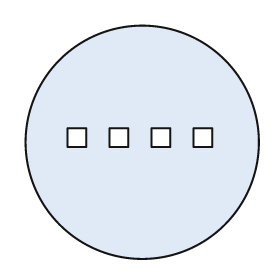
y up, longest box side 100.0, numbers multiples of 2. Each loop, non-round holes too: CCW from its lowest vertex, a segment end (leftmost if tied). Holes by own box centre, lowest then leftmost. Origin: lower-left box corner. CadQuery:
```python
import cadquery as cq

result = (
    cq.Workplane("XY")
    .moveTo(50.0, 50.0)
    .circle(50.0)
    .moveTo(18.0, 48.0)
    .lineTo(26.0, 48.0)
    .lineTo(26.0, 56.0)
    .lineTo(18.0, 56.0)
    .close()
    .moveTo(36.0, 48.0)
    .lineTo(44.0, 48.0)
    .lineTo(44.0, 56.0)
    .lineTo(36.0, 56.0)
    .close()
    .moveTo(54.0, 48.0)
    .lineTo(62.0, 48.0)
    .lineTo(62.0, 56.0)
    .lineTo(54.0, 56.0)
    .close()
    .moveTo(72.0, 48.0)
    .lineTo(80.0, 48.0)
    .lineTo(80.0, 56.0)
    .lineTo(72.0, 56.0)
    .close()
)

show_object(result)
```